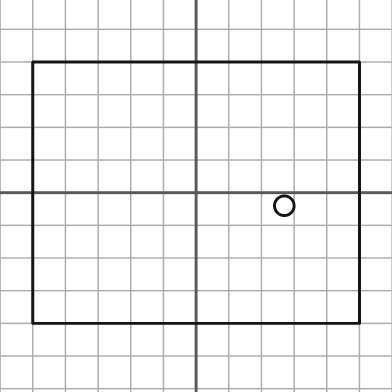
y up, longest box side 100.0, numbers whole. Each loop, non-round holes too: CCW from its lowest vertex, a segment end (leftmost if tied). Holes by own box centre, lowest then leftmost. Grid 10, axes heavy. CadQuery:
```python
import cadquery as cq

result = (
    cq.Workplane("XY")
    .moveTo(-50.0, -40.0)
    .lineTo(50.0, -40.0)
    .lineTo(50.0, 40.0)
    .lineTo(-50.0, 40.0)
    .close()
    .moveTo(27.0, -4.0)
    .circle(3.0)
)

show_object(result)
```